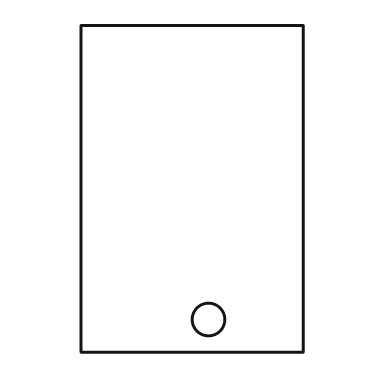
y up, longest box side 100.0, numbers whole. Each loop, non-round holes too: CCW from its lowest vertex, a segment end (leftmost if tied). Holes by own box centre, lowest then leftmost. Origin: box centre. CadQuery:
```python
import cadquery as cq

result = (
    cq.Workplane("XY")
    .moveTo(-34.0, -50.0)
    .lineTo(34.0, -50.0)
    .lineTo(34.0, 50.0)
    .lineTo(-34.0, 50.0)
    .close()
    .moveTo(5.0, -40.0)
    .circle(5.0)
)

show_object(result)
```